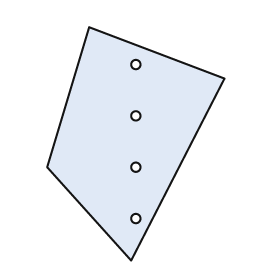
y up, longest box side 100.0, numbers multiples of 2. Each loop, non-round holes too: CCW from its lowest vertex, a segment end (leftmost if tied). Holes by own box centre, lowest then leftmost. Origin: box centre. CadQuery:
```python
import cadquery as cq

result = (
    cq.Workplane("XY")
    .moveTo(-2.0, -50.0)
    .lineTo(38.0, 28.0)
    .lineTo(-20.0, 50.0)
    .lineTo(-38.0, -10.0)
    .close()
    .moveTo(0.0, -32.0)
    .circle(2.0)
    .moveTo(0.0, -10.0)
    .circle(2.0)
    .moveTo(0.0, 12.0)
    .circle(2.0)
    .moveTo(0.0, 34.0)
    .circle(2.0)
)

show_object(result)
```